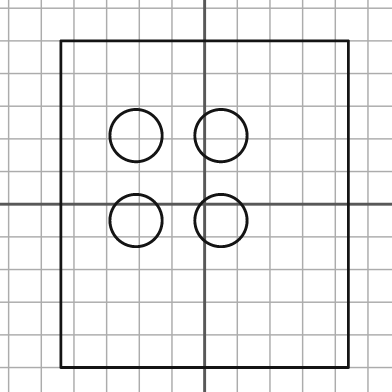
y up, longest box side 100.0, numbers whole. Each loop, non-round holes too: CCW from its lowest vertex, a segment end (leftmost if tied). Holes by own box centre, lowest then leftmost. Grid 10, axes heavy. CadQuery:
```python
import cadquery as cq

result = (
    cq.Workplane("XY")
    .moveTo(-44.0, -50.0)
    .lineTo(44.0, -50.0)
    .lineTo(44.0, 50.0)
    .lineTo(-44.0, 50.0)
    .close()
    .moveTo(-21.0, -5.0)
    .circle(8.0)
    .moveTo(5.0, -5.0)
    .circle(8.0)
    .moveTo(-21.0, 21.0)
    .circle(8.0)
    .moveTo(5.0, 21.0)
    .circle(8.0)
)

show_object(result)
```